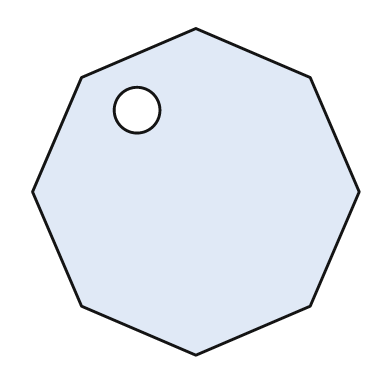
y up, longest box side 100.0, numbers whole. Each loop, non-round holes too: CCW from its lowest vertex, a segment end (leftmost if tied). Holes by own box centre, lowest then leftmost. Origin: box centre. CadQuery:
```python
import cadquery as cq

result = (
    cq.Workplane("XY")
    .moveTo(0.0, -50.0)
    .lineTo(35.0, -35.0)
    .lineTo(50.0, 0.0)
    .lineTo(35.0, 35.0)
    .lineTo(0.0, 50.0)
    .lineTo(-35.0, 35.0)
    .lineTo(-50.0, 0.0)
    .lineTo(-35.0, -35.0)
    .close()
    .moveTo(-18.0, 25.0)
    .circle(7.0)
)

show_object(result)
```